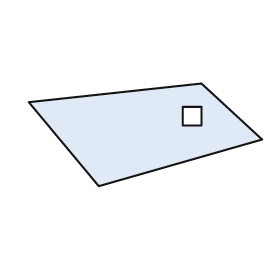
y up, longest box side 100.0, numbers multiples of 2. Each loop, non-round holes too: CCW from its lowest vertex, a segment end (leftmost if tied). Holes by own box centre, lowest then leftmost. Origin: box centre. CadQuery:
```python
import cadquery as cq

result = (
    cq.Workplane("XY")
    .moveTo(-20.0, -22.0)
    .lineTo(50.0, -2.0)
    .lineTo(24.0, 22.0)
    .lineTo(-50.0, 14.0)
    .close()
    .moveTo(16.0, 4.0)
    .lineTo(24.0, 4.0)
    .lineTo(24.0, 12.0)
    .lineTo(16.0, 12.0)
    .close()
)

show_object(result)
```